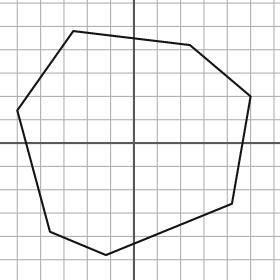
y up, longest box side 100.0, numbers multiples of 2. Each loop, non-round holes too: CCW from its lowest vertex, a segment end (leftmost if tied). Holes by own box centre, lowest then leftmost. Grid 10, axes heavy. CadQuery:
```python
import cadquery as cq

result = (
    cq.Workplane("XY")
    .moveTo(-12.0, -48.0)
    .lineTo(42.0, -26.0)
    .lineTo(50.0, 20.0)
    .lineTo(24.0, 42.0)
    .lineTo(-26.0, 48.0)
    .lineTo(-50.0, 14.0)
    .lineTo(-36.0, -38.0)
    .close()
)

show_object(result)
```